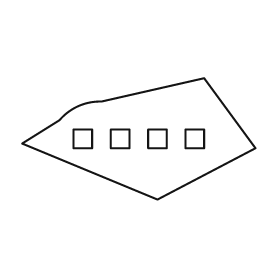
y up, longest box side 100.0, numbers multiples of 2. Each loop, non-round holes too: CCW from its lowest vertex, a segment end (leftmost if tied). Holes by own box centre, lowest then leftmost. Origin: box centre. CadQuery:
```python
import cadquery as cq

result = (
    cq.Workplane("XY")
    .moveTo(8.0, -26.0)
    .lineTo(50.0, -4.0)
    .lineTo(28.0, 26.0)
    .lineTo(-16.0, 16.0)
    .threePointArc((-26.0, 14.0), (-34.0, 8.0))
    .lineTo(-50.0, -2.0)
    .close()
    .moveTo(-28.0, -4.0)
    .lineTo(-20.0, -4.0)
    .lineTo(-20.0, 4.0)
    .lineTo(-28.0, 4.0)
    .close()
    .moveTo(-12.0, -4.0)
    .lineTo(-4.0, -4.0)
    .lineTo(-4.0, 4.0)
    .lineTo(-12.0, 4.0)
    .close()
    .moveTo(4.0, -4.0)
    .lineTo(12.0, -4.0)
    .lineTo(12.0, 4.0)
    .lineTo(4.0, 4.0)
    .close()
    .moveTo(20.0, -4.0)
    .lineTo(28.0, -4.0)
    .lineTo(28.0, 4.0)
    .lineTo(20.0, 4.0)
    .close()
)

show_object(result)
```